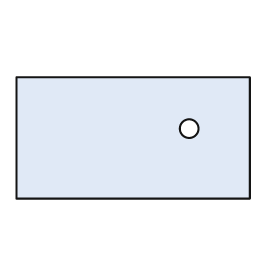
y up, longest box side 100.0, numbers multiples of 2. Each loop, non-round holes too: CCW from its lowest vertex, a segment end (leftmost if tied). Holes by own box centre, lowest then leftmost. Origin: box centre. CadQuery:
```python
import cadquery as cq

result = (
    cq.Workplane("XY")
    .moveTo(-50.0, -26.0)
    .lineTo(50.0, -26.0)
    .lineTo(50.0, 26.0)
    .lineTo(-50.0, 26.0)
    .close()
    .moveTo(24.0, 4.0)
    .circle(4.0)
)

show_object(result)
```